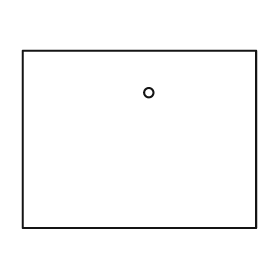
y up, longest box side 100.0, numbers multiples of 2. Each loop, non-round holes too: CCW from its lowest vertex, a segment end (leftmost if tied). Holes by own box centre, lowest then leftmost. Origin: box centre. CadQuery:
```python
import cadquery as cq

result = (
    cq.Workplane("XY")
    .moveTo(-50.0, -38.0)
    .lineTo(50.0, -38.0)
    .lineTo(50.0, 38.0)
    .lineTo(-50.0, 38.0)
    .close()
    .moveTo(4.0, 20.0)
    .circle(2.0)
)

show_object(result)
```